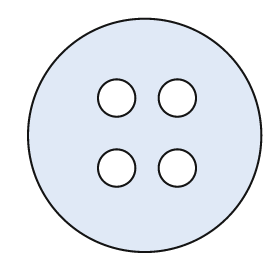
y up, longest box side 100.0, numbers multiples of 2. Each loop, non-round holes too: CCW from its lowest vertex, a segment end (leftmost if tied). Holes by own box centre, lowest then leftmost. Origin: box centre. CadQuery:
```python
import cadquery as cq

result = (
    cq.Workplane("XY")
    .moveTo(0.0, 0.0)
    .circle(50.0)
    .moveTo(-12.0, -14.0)
    .circle(8.0)
    .moveTo(14.0, -14.0)
    .circle(8.0)
    .moveTo(-12.0, 16.0)
    .circle(8.0)
    .moveTo(14.0, 16.0)
    .circle(8.0)
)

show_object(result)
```